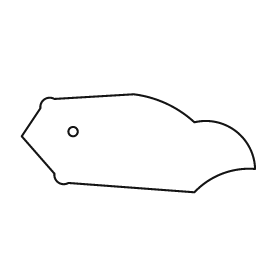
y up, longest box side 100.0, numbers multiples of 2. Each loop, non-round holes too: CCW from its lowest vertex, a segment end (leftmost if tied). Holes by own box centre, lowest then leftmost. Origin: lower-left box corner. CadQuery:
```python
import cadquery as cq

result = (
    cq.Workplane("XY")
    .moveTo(74.0, 0.0)
    .threePointArc((86.0, 8.0), (100.0, 10.0))
    .threePointArc((92.0, 26.0), (74.0, 30.0))
    .threePointArc((62.0, 38.0), (48.0, 42.0))
    .lineTo(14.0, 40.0)
    .threePointArc((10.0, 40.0), (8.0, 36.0))
    .lineTo(0.0, 24.0)
    .lineTo(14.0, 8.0)
    .threePointArc((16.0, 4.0), (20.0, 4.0))
    .close()
    .moveTo(22.0, 26.0)
    .circle(2.0)
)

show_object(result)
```